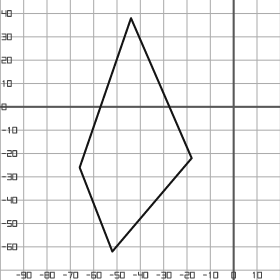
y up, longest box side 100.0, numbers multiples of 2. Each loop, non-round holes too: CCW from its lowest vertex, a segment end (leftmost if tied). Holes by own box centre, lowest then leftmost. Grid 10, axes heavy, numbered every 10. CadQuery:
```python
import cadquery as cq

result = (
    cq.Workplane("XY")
    .moveTo(-52.0, -62.0)
    .lineTo(-18.0, -22.0)
    .lineTo(-44.0, 38.0)
    .lineTo(-66.0, -26.0)
    .close()
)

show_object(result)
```